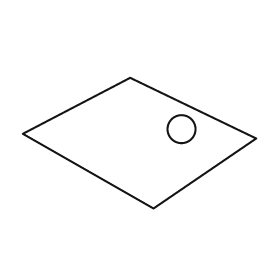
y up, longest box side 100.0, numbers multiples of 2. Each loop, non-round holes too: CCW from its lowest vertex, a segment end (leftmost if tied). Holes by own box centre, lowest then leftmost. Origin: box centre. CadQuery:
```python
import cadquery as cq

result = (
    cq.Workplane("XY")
    .moveTo(6.0, -28.0)
    .lineTo(50.0, 2.0)
    .lineTo(-4.0, 28.0)
    .lineTo(-50.0, 4.0)
    .close()
    .moveTo(18.0, 6.0)
    .circle(6.0)
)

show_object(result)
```